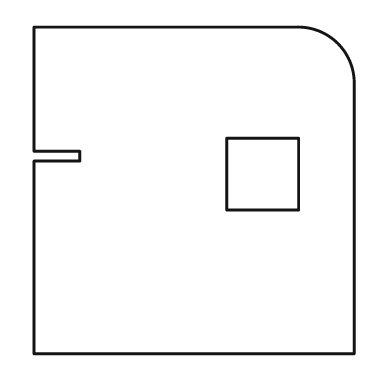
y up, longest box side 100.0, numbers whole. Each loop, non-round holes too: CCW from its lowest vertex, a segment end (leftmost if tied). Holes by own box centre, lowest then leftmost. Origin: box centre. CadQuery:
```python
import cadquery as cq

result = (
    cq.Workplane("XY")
    .moveTo(-49.0, -50.0)
    .lineTo(49.0, -50.0)
    .lineTo(49.0, 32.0)
    .threePointArc((44.0, 45.0), (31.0, 50.0))
    .lineTo(-49.0, 50.0)
    .lineTo(-49.0, 12.0)
    .lineTo(-35.0, 12.0)
    .lineTo(-35.0, 9.0)
    .lineTo(-49.0, 9.0)
    .close()
    .moveTo(10.0, -6.0)
    .lineTo(32.0, -6.0)
    .lineTo(32.0, 16.0)
    .lineTo(10.0, 16.0)
    .close()
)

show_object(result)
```